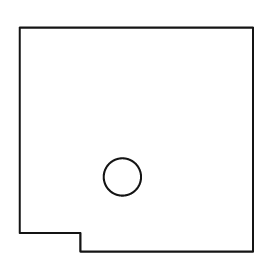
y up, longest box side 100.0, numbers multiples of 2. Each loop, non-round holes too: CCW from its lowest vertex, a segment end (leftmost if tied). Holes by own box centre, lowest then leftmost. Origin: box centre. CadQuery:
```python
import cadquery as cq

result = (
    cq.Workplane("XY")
    .moveTo(-24.0, -48.0)
    .lineTo(50.0, -48.0)
    .lineTo(50.0, 48.0)
    .lineTo(-50.0, 48.0)
    .lineTo(-50.0, -40.0)
    .lineTo(-24.0, -40.0)
    .close()
    .moveTo(-6.0, -16.0)
    .circle(8.0)
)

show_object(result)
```